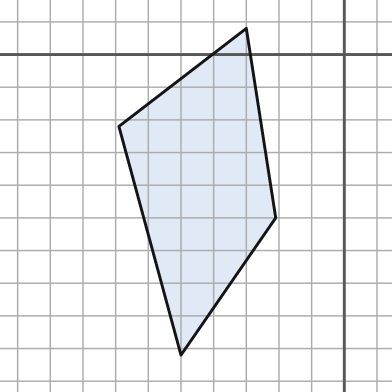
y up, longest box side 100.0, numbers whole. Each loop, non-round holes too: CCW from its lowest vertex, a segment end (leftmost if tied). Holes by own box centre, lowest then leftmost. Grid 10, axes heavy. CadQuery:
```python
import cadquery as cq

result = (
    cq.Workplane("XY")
    .moveTo(-50.0, -92.0)
    .lineTo(-21.0, -50.0)
    .lineTo(-30.0, 8.0)
    .lineTo(-69.0, -22.0)
    .close()
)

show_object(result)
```